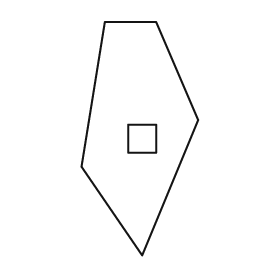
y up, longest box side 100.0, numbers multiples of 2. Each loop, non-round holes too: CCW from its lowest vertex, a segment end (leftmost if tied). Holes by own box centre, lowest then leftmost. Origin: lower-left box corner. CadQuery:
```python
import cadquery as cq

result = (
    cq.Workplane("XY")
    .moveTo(26.0, 0.0)
    .lineTo(50.0, 58.0)
    .lineTo(32.0, 100.0)
    .lineTo(10.0, 100.0)
    .lineTo(0.0, 38.0)
    .close()
    .moveTo(20.0, 44.0)
    .lineTo(32.0, 44.0)
    .lineTo(32.0, 56.0)
    .lineTo(20.0, 56.0)
    .close()
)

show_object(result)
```